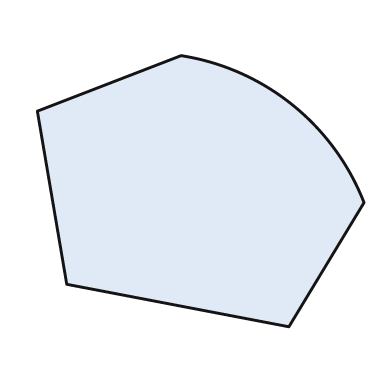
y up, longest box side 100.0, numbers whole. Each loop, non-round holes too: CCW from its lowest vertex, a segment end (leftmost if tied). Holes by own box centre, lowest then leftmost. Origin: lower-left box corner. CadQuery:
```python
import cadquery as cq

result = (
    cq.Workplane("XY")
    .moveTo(77.0, 0.0)
    .lineTo(100.0, 38.0)
    .threePointArc((78.0, 68.0), (44.0, 83.0))
    .lineTo(0.0, 66.0)
    .lineTo(9.0, 13.0)
    .close()
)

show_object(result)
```